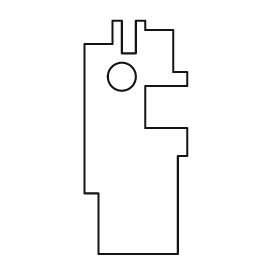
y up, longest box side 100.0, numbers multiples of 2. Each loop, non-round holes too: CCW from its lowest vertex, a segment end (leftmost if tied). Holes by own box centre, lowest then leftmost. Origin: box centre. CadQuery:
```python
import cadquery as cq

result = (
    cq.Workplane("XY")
    .moveTo(-16.0, -50.0)
    .lineTo(18.0, -50.0)
    .lineTo(18.0, -8.0)
    .lineTo(22.0, -8.0)
    .lineTo(22.0, 4.0)
    .lineTo(4.0, 4.0)
    .lineTo(4.0, 22.0)
    .lineTo(22.0, 22.0)
    .lineTo(22.0, 28.0)
    .lineTo(16.0, 28.0)
    .lineTo(16.0, 46.0)
    .lineTo(4.0, 46.0)
    .lineTo(4.0, 50.0)
    .lineTo(0.0, 50.0)
    .lineTo(0.0, 36.0)
    .lineTo(-6.0, 36.0)
    .lineTo(-6.0, 50.0)
    .lineTo(-10.0, 50.0)
    .lineTo(-10.0, 40.0)
    .lineTo(-22.0, 40.0)
    .lineTo(-22.0, -24.0)
    .lineTo(-16.0, -24.0)
    .close()
    .moveTo(-6.0, 26.0)
    .circle(6.0)
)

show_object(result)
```